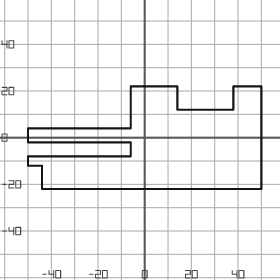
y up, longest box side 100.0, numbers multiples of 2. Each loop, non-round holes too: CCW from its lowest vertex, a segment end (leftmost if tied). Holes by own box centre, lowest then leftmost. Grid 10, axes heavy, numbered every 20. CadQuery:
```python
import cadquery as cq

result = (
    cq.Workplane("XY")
    .moveTo(-44.0, -22.0)
    .lineTo(50.0, -22.0)
    .lineTo(50.0, 22.0)
    .lineTo(38.0, 22.0)
    .lineTo(38.0, 12.0)
    .lineTo(14.0, 12.0)
    .lineTo(14.0, 22.0)
    .lineTo(-6.0, 22.0)
    .lineTo(-6.0, 4.0)
    .lineTo(-50.0, 4.0)
    .lineTo(-50.0, -2.0)
    .lineTo(-6.0, -2.0)
    .lineTo(-6.0, -8.0)
    .lineTo(-50.0, -8.0)
    .lineTo(-50.0, -12.0)
    .lineTo(-44.0, -12.0)
    .close()
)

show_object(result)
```